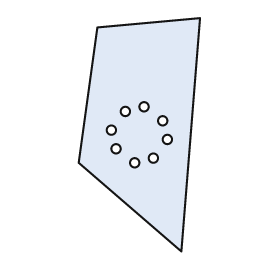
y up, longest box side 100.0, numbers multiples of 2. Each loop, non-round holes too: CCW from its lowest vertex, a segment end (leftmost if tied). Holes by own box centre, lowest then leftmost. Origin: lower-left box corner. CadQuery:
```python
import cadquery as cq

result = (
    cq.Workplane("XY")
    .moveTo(44.0, 0.0)
    .lineTo(52.0, 100.0)
    .lineTo(8.0, 96.0)
    .lineTo(0.0, 38.0)
    .close()
    .moveTo(24.0, 38.0)
    .circle(2.0)
    .moveTo(32.0, 40.0)
    .circle(2.0)
    .moveTo(16.0, 44.0)
    .circle(2.0)
    .moveTo(38.0, 48.0)
    .circle(2.0)
    .moveTo(14.0, 52.0)
    .circle(2.0)
    .moveTo(36.0, 56.0)
    .circle(2.0)
    .moveTo(20.0, 60.0)
    .circle(2.0)
    .moveTo(28.0, 62.0)
    .circle(2.0)
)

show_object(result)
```